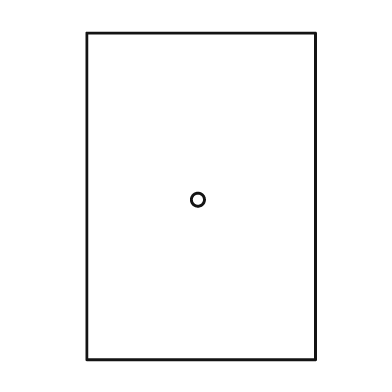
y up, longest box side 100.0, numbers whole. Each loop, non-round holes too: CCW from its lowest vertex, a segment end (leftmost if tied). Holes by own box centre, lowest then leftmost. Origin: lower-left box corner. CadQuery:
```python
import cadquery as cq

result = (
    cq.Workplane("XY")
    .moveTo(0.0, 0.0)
    .lineTo(70.0, 0.0)
    .lineTo(70.0, 100.0)
    .lineTo(0.0, 100.0)
    .close()
    .moveTo(34.0, 49.0)
    .circle(2.0)
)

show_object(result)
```